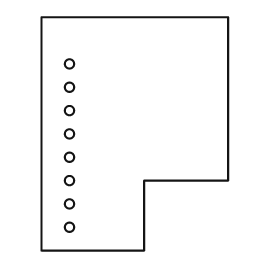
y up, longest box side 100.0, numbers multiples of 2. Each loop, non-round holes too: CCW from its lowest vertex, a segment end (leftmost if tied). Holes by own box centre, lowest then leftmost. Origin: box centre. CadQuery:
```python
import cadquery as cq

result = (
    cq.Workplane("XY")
    .moveTo(-40.0, -50.0)
    .lineTo(4.0, -50.0)
    .lineTo(4.0, -20.0)
    .lineTo(40.0, -20.0)
    .lineTo(40.0, 50.0)
    .lineTo(-40.0, 50.0)
    .close()
    .moveTo(-28.0, -40.0)
    .circle(2.0)
    .moveTo(-28.0, -30.0)
    .circle(2.0)
    .moveTo(-28.0, -20.0)
    .circle(2.0)
    .moveTo(-28.0, -10.0)
    .circle(2.0)
    .moveTo(-28.0, 0.0)
    .circle(2.0)
    .moveTo(-28.0, 10.0)
    .circle(2.0)
    .moveTo(-28.0, 20.0)
    .circle(2.0)
    .moveTo(-28.0, 30.0)
    .circle(2.0)
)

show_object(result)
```